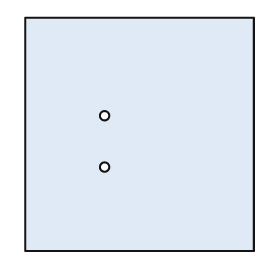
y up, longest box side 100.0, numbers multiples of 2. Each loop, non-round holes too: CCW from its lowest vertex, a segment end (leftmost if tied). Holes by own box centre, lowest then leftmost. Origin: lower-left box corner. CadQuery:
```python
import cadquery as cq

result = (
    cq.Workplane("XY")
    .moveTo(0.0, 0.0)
    .lineTo(98.0, 0.0)
    .lineTo(98.0, 100.0)
    .lineTo(0.0, 100.0)
    .close()
    .moveTo(34.0, 36.0)
    .circle(2.0)
    .moveTo(34.0, 58.0)
    .circle(2.0)
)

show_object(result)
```